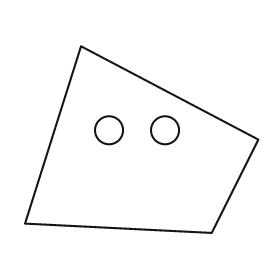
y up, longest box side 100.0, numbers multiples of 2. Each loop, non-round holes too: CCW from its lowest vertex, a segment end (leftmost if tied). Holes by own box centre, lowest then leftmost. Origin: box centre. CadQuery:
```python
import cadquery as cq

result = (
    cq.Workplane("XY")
    .moveTo(30.0, -40.0)
    .lineTo(50.0, 0.0)
    .lineTo(-26.0, 40.0)
    .lineTo(-50.0, -36.0)
    .close()
    .moveTo(-14.0, 4.0)
    .circle(6.0)
    .moveTo(10.0, 4.0)
    .circle(6.0)
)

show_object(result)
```